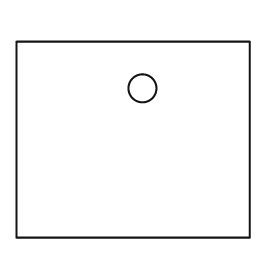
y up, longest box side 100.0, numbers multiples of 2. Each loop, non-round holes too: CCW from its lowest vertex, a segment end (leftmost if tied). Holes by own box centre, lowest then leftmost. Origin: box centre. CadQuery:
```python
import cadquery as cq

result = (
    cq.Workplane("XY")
    .moveTo(-50.0, -42.0)
    .lineTo(50.0, -42.0)
    .lineTo(50.0, 42.0)
    .lineTo(-50.0, 42.0)
    .close()
    .moveTo(4.0, 22.0)
    .circle(6.0)
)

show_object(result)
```